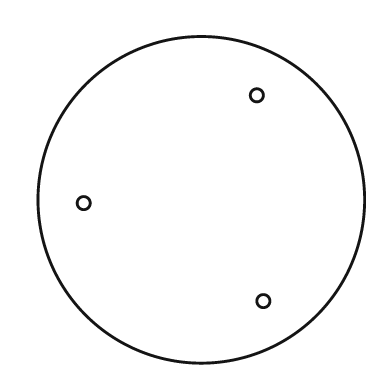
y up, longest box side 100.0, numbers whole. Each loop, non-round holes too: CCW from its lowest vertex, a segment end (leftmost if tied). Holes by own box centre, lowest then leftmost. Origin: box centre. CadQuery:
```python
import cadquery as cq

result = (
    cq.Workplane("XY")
    .moveTo(0.0, 0.0)
    .circle(50.0)
    .moveTo(19.0, -31.0)
    .circle(2.0)
    .moveTo(-36.0, -1.0)
    .circle(2.0)
    .moveTo(17.0, 32.0)
    .circle(2.0)
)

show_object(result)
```